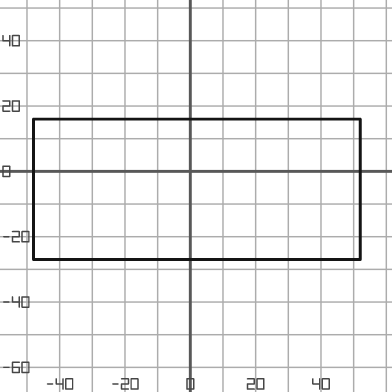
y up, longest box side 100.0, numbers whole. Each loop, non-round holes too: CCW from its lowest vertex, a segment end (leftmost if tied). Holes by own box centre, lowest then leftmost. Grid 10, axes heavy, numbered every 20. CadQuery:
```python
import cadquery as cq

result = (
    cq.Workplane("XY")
    .moveTo(-48.0, -27.0)
    .lineTo(52.0, -27.0)
    .lineTo(52.0, 16.0)
    .lineTo(-48.0, 16.0)
    .close()
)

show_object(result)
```